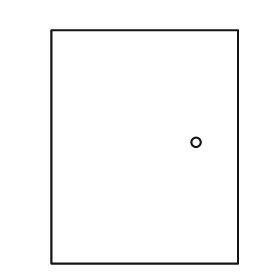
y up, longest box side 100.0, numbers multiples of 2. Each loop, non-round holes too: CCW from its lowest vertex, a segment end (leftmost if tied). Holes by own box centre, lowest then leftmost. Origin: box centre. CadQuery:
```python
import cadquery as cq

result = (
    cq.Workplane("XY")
    .moveTo(-40.0, -50.0)
    .lineTo(40.0, -50.0)
    .lineTo(40.0, 50.0)
    .lineTo(-40.0, 50.0)
    .close()
    .moveTo(22.0, 2.0)
    .circle(2.0)
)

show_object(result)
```